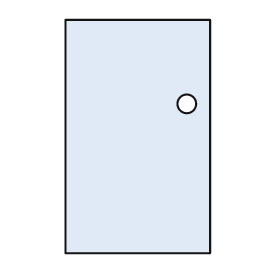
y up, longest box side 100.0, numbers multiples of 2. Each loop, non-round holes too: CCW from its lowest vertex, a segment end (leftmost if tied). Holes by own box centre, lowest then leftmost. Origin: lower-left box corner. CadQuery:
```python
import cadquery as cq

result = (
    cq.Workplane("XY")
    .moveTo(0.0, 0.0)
    .lineTo(62.0, 0.0)
    .lineTo(62.0, 100.0)
    .lineTo(0.0, 100.0)
    .close()
    .moveTo(52.0, 64.0)
    .circle(4.0)
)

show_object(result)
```